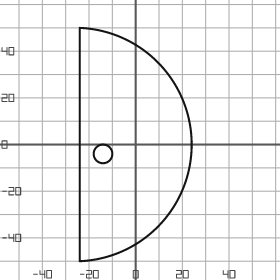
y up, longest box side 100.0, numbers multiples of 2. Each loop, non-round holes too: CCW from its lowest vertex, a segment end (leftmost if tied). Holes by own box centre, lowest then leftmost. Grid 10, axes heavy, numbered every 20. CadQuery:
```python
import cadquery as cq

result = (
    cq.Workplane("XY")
    .moveTo(-24.0, -50.0)
    .threePointArc((24.0, 0.0), (-24.0, 50.0))
    .close()
    .moveTo(-14.0, -4.0)
    .circle(4.0)
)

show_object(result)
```